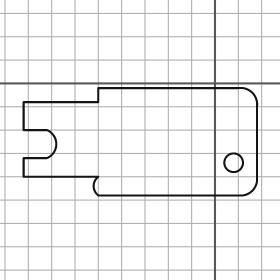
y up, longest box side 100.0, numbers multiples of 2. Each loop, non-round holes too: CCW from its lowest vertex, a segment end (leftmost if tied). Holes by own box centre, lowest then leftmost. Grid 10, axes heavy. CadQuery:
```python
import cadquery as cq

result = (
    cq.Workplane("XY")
    .moveTo(-50.0, -48.0)
    .lineTo(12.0, -48.0)
    .threePointArc((16.0, -46.0), (18.0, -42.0))
    .lineTo(18.0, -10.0)
    .threePointArc((16.0, -4.0), (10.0, -2.0))
    .lineTo(-50.0, -2.0)
    .lineTo(-50.0, -8.0)
    .lineTo(-82.0, -8.0)
    .lineTo(-82.0, -20.0)
    .lineTo(-72.0, -20.0)
    .threePointArc((-68.0, -26.0), (-72.0, -32.0))
    .lineTo(-82.0, -32.0)
    .lineTo(-82.0, -40.0)
    .lineTo(-50.0, -40.0)
    .threePointArc((-52.0, -44.0), (-50.0, -48.0))
    .close()
    .moveTo(8.0, -34.0)
    .circle(4.0)
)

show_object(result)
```